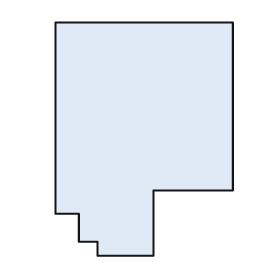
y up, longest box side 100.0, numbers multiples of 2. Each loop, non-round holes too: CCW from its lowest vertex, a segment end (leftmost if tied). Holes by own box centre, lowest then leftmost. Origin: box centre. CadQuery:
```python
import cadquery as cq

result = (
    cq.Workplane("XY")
    .moveTo(-20.0, -50.0)
    .lineTo(4.0, -50.0)
    .lineTo(4.0, -22.0)
    .lineTo(38.0, -22.0)
    .lineTo(38.0, 50.0)
    .lineTo(-38.0, 50.0)
    .lineTo(-38.0, -32.0)
    .lineTo(-28.0, -32.0)
    .lineTo(-28.0, -44.0)
    .lineTo(-20.0, -44.0)
    .close()
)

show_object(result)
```